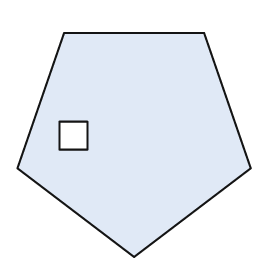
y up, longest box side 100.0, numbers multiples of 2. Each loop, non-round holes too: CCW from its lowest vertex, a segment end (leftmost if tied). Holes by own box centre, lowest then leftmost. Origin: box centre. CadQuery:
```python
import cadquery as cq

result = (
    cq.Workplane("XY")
    .moveTo(0.0, -48.0)
    .lineTo(50.0, -10.0)
    .lineTo(30.0, 48.0)
    .lineTo(-30.0, 48.0)
    .lineTo(-50.0, -10.0)
    .close()
    .moveTo(-32.0, -2.0)
    .lineTo(-20.0, -2.0)
    .lineTo(-20.0, 10.0)
    .lineTo(-32.0, 10.0)
    .close()
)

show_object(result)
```